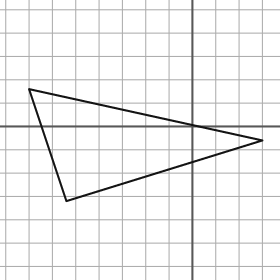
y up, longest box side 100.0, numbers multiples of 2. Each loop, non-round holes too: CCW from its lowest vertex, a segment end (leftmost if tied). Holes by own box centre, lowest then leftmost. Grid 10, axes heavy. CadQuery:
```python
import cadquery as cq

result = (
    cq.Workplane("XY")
    .moveTo(-54.0, -32.0)
    .lineTo(30.0, -6.0)
    .lineTo(-70.0, 16.0)
    .close()
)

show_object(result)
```